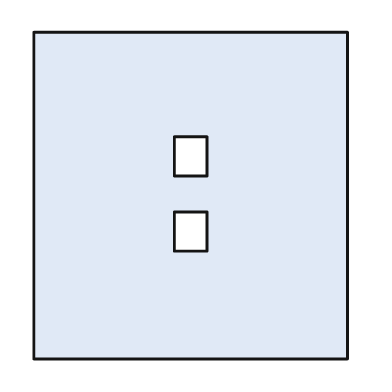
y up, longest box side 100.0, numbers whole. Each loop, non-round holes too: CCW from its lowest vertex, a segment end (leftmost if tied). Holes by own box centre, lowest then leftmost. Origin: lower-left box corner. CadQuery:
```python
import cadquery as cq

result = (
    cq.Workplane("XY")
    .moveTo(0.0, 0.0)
    .lineTo(96.0, 0.0)
    .lineTo(96.0, 100.0)
    .lineTo(0.0, 100.0)
    .close()
    .moveTo(43.0, 33.0)
    .lineTo(53.0, 33.0)
    .lineTo(53.0, 45.0)
    .lineTo(43.0, 45.0)
    .close()
    .moveTo(43.0, 56.0)
    .lineTo(53.0, 56.0)
    .lineTo(53.0, 68.0)
    .lineTo(43.0, 68.0)
    .close()
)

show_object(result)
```